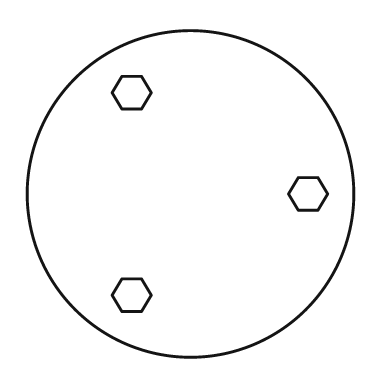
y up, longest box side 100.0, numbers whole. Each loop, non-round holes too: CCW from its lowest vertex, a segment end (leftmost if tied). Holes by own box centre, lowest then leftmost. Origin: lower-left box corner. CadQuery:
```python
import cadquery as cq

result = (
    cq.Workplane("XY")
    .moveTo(50.0, 50.0)
    .circle(50.0)
    .moveTo(29.0, 14.0)
    .lineTo(35.0, 14.0)
    .lineTo(38.0, 19.0)
    .lineTo(35.0, 24.0)
    .lineTo(29.0, 24.0)
    .lineTo(26.0, 19.0)
    .close()
    .moveTo(83.0, 45.0)
    .lineTo(89.0, 45.0)
    .lineTo(92.0, 50.0)
    .lineTo(89.0, 55.0)
    .lineTo(83.0, 55.0)
    .lineTo(80.0, 50.0)
    .close()
    .moveTo(29.0, 76.0)
    .lineTo(35.0, 76.0)
    .lineTo(38.0, 81.0)
    .lineTo(35.0, 86.0)
    .lineTo(29.0, 86.0)
    .lineTo(26.0, 81.0)
    .close()
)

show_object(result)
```